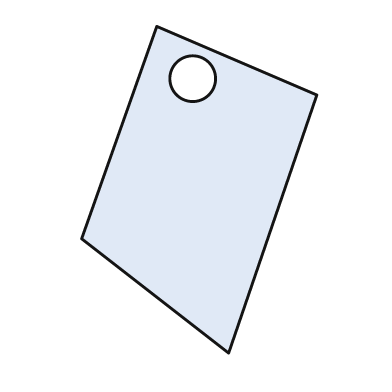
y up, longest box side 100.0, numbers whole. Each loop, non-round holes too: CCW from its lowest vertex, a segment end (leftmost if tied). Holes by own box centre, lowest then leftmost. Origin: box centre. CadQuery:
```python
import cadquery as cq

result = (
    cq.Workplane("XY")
    .moveTo(9.0, -50.0)
    .lineTo(36.0, 29.0)
    .lineTo(-13.0, 50.0)
    .lineTo(-36.0, -15.0)
    .close()
    .moveTo(-2.0, 34.0)
    .circle(7.0)
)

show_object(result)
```